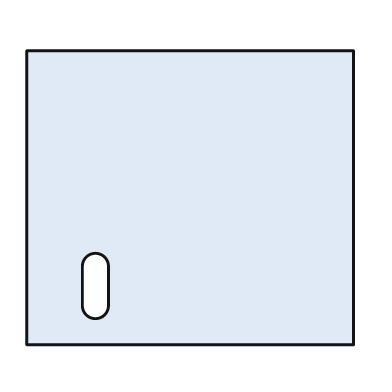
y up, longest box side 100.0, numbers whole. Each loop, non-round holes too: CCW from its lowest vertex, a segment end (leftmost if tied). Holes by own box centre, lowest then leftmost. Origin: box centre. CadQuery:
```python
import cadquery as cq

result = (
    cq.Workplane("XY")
    .moveTo(-50.0, -45.0)
    .lineTo(50.0, -45.0)
    .lineTo(50.0, 45.0)
    .lineTo(-50.0, 45.0)
    .close()
    .moveTo(-33.0, -33.0)
    .threePointArc((-29.0, -37.0), (-25.0, -33.0))
    .lineTo(-25.0, -21.0)
    .threePointArc((-29.0, -17.0), (-33.0, -21.0))
    .close()
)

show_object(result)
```